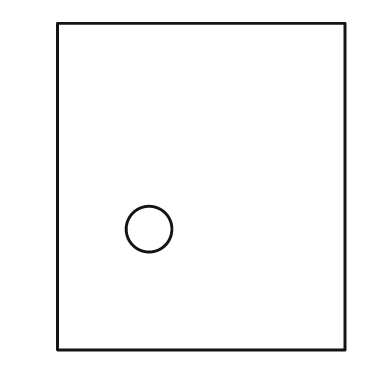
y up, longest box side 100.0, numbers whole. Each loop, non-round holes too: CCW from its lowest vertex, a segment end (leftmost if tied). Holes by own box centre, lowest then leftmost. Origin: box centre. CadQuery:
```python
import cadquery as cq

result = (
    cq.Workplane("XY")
    .moveTo(-44.0, -50.0)
    .lineTo(44.0, -50.0)
    .lineTo(44.0, 50.0)
    .lineTo(-44.0, 50.0)
    .close()
    .moveTo(-16.0, -13.0)
    .circle(7.0)
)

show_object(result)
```